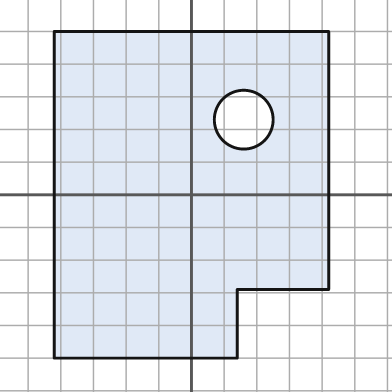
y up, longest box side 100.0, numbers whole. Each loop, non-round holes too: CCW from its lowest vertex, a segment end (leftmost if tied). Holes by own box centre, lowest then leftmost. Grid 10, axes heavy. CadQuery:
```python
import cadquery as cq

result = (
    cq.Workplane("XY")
    .moveTo(-42.0, -50.0)
    .lineTo(14.0, -50.0)
    .lineTo(14.0, -29.0)
    .lineTo(42.0, -29.0)
    .lineTo(42.0, 50.0)
    .lineTo(-42.0, 50.0)
    .close()
    .moveTo(16.0, 23.0)
    .circle(9.0)
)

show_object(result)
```